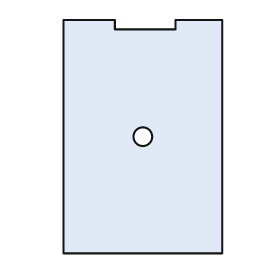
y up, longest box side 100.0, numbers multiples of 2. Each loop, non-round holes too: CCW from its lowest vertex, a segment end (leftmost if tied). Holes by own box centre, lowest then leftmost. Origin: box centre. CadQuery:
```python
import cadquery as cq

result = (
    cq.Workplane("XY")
    .moveTo(-34.0, -50.0)
    .lineTo(34.0, -50.0)
    .lineTo(34.0, 50.0)
    .lineTo(14.0, 50.0)
    .lineTo(14.0, 46.0)
    .lineTo(-12.0, 46.0)
    .lineTo(-12.0, 50.0)
    .lineTo(-34.0, 50.0)
    .close()
    .moveTo(0.0, 0.0)
    .circle(4.0)
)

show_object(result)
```